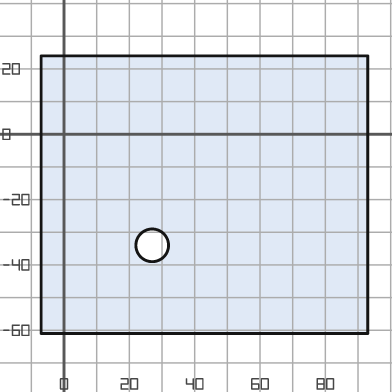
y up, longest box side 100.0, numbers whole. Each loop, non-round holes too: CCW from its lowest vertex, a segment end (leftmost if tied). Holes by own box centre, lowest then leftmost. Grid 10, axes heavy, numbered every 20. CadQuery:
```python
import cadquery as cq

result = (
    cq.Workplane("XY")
    .moveTo(-7.0, -61.0)
    .lineTo(93.0, -61.0)
    .lineTo(93.0, 24.0)
    .lineTo(-7.0, 24.0)
    .close()
    .moveTo(27.0, -34.0)
    .circle(5.0)
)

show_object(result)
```